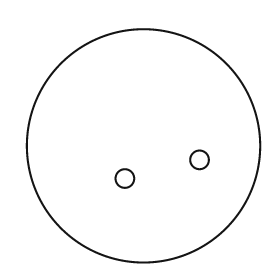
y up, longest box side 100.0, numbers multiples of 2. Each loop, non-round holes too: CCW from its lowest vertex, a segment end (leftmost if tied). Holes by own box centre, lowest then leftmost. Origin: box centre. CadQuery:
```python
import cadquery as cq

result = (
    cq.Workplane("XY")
    .moveTo(0.0, 0.0)
    .circle(50.0)
    .moveTo(-8.0, -14.0)
    .circle(4.0)
    .moveTo(24.0, -6.0)
    .circle(4.0)
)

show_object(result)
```